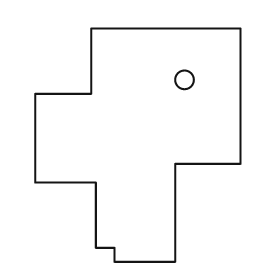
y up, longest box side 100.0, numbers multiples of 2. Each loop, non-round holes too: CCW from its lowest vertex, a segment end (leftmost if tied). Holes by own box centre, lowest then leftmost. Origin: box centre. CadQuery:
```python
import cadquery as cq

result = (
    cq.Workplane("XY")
    .moveTo(-10.0, -50.0)
    .lineTo(16.0, -50.0)
    .lineTo(16.0, -8.0)
    .lineTo(44.0, -8.0)
    .lineTo(44.0, 50.0)
    .lineTo(-20.0, 50.0)
    .lineTo(-20.0, 22.0)
    .lineTo(-44.0, 22.0)
    .lineTo(-44.0, -16.0)
    .lineTo(-18.0, -16.0)
    .lineTo(-18.0, -44.0)
    .lineTo(-10.0, -44.0)
    .close()
    .moveTo(20.0, 28.0)
    .circle(4.0)
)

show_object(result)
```